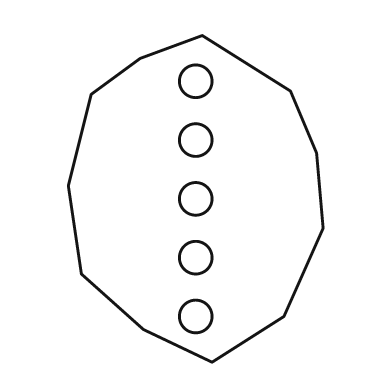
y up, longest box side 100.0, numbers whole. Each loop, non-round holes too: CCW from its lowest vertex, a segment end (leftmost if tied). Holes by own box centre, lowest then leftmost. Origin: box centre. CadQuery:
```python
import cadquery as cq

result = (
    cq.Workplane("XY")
    .moveTo(5.0, -50.0)
    .lineTo(27.0, -36.0)
    .lineTo(39.0, -9.0)
    .lineTo(37.0, 14.0)
    .lineTo(29.0, 33.0)
    .lineTo(2.0, 50.0)
    .lineTo(-17.0, 43.0)
    .lineTo(-32.0, 32.0)
    .lineTo(-39.0, 4.0)
    .lineTo(-35.0, -23.0)
    .lineTo(-16.0, -40.0)
    .close()
    .moveTo(0.0, -36.0)
    .circle(5.0)
    .moveTo(0.0, -18.0)
    .circle(5.0)
    .moveTo(0.0, 0.0)
    .circle(5.0)
    .moveTo(0.0, 18.0)
    .circle(5.0)
    .moveTo(0.0, 36.0)
    .circle(5.0)
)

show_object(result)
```